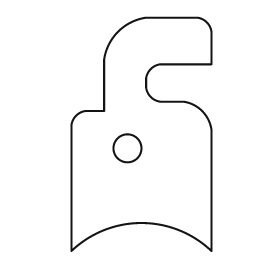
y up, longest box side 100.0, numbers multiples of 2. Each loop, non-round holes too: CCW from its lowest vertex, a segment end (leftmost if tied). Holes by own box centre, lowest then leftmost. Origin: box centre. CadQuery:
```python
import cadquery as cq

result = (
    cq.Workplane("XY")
    .moveTo(-30.0, -50.0)
    .threePointArc((0.0, -38.0), (30.0, -50.0))
    .lineTo(30.0, 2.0)
    .threePointArc((26.0, 10.0), (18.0, 14.0))
    .lineTo(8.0, 14.0)
    .threePointArc((4.0, 16.0), (2.0, 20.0))
    .lineTo(2.0, 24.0)
    .threePointArc((4.0, 28.0), (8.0, 30.0))
    .lineTo(30.0, 30.0)
    .lineTo(30.0, 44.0)
    .threePointArc((28.0, 48.0), (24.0, 50.0))
    .lineTo(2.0, 50.0)
    .threePointArc((-10.0, 44.0), (-16.0, 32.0))
    .lineTo(-16.0, 10.0)
    .lineTo(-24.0, 10.0)
    .threePointArc((-28.0, 8.0), (-30.0, 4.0))
    .close()
    .moveTo(-6.0, -6.0)
    .circle(6.0)
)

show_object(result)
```